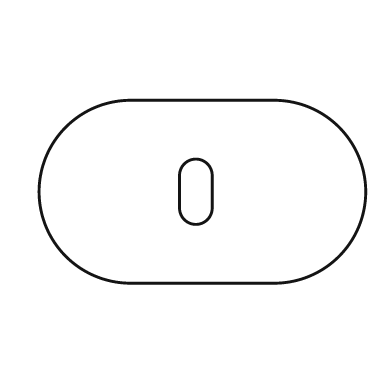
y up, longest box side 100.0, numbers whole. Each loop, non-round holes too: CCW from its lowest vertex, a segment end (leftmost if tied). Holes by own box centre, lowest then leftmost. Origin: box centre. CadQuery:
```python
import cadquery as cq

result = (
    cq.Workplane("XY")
    .moveTo(-22.0, -28.0)
    .lineTo(22.0, -28.0)
    .threePointArc((50.0, 0.0), (22.0, 28.0))
    .lineTo(-22.0, 28.0)
    .threePointArc((-50.0, 0.0), (-22.0, -28.0))
    .close()
    .moveTo(-7.0, -5.0)
    .threePointArc((-2.0, -10.0), (3.0, -5.0))
    .lineTo(3.0, 5.0)
    .threePointArc((-2.0, 10.0), (-7.0, 5.0))
    .close()
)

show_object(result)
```